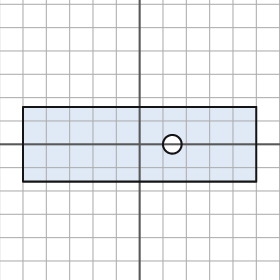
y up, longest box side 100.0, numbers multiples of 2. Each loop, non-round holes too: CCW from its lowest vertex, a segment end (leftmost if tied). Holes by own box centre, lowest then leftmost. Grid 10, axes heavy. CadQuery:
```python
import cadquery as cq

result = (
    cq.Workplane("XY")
    .moveTo(-50.0, -16.0)
    .lineTo(50.0, -16.0)
    .lineTo(50.0, 16.0)
    .lineTo(-50.0, 16.0)
    .close()
    .moveTo(14.0, 0.0)
    .circle(4.0)
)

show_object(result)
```